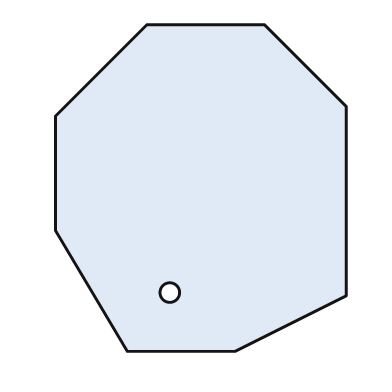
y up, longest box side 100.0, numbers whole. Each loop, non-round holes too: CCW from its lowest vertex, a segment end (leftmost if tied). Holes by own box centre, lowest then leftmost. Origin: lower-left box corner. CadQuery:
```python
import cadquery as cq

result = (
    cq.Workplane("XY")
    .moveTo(22.0, 0.0)
    .lineTo(55.0, 0.0)
    .lineTo(89.0, 17.0)
    .lineTo(89.0, 75.0)
    .lineTo(64.0, 100.0)
    .lineTo(28.0, 100.0)
    .lineTo(0.0, 72.0)
    .lineTo(0.0, 37.0)
    .close()
    .moveTo(35.0, 18.0)
    .circle(3.0)
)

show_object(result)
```